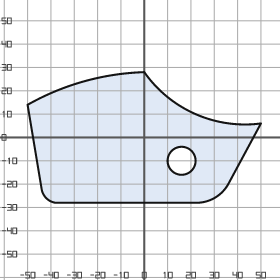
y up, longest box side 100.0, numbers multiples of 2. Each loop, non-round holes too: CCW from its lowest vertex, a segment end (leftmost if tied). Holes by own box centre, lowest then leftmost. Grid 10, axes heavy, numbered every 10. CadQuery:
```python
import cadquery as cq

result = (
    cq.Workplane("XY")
    .moveTo(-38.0, -28.0)
    .lineTo(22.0, -28.0)
    .threePointArc((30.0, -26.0), (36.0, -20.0))
    .lineTo(50.0, 6.0)
    .threePointArc((22.0, 10.0), (0.0, 28.0))
    .threePointArc((-26.0, 24.0), (-50.0, 14.0))
    .lineTo(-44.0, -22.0)
    .threePointArc((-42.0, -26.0), (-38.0, -28.0))
    .close()
    .moveTo(16.0, -10.0)
    .circle(6.0)
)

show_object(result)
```